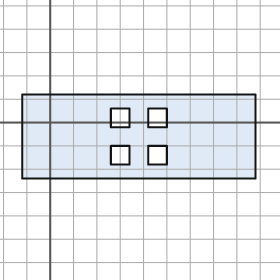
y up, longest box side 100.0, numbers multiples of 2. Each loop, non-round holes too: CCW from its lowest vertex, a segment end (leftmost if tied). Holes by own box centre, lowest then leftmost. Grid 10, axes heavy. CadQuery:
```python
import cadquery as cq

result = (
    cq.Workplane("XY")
    .moveTo(-12.0, -24.0)
    .lineTo(88.0, -24.0)
    .lineTo(88.0, 12.0)
    .lineTo(-12.0, 12.0)
    .close()
    .moveTo(26.0, -18.0)
    .lineTo(34.0, -18.0)
    .lineTo(34.0, -10.0)
    .lineTo(26.0, -10.0)
    .close()
    .moveTo(42.0, -18.0)
    .lineTo(50.0, -18.0)
    .lineTo(50.0, -10.0)
    .lineTo(42.0, -10.0)
    .close()
    .moveTo(26.0, -2.0)
    .lineTo(34.0, -2.0)
    .lineTo(34.0, 6.0)
    .lineTo(26.0, 6.0)
    .close()
    .moveTo(42.0, -2.0)
    .lineTo(50.0, -2.0)
    .lineTo(50.0, 6.0)
    .lineTo(42.0, 6.0)
    .close()
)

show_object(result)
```